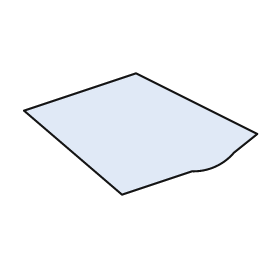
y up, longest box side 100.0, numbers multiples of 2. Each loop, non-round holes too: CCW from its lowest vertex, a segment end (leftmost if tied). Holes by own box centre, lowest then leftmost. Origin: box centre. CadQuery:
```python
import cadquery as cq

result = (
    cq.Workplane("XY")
    .moveTo(-8.0, -26.0)
    .lineTo(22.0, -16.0)
    .threePointArc((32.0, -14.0), (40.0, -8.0))
    .lineTo(50.0, 0.0)
    .lineTo(-2.0, 26.0)
    .lineTo(-50.0, 10.0)
    .close()
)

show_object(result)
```